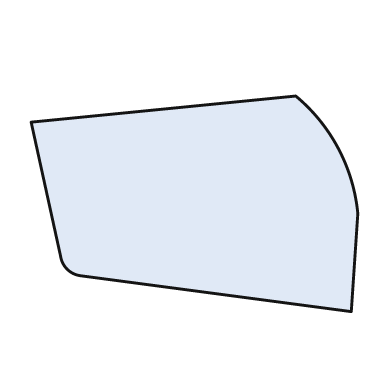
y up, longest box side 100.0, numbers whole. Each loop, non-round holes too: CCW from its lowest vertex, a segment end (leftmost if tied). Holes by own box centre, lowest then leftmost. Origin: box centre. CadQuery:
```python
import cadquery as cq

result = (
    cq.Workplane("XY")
    .moveTo(48.0, -33.0)
    .lineTo(50.0, -3.0)
    .threePointArc((44.0, 17.0), (31.0, 33.0))
    .lineTo(-50.0, 25.0)
    .lineTo(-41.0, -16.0)
    .threePointArc((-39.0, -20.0), (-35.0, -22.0))
    .close()
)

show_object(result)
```